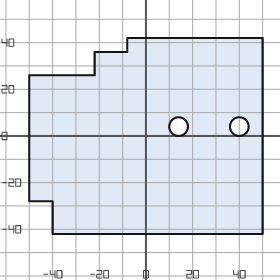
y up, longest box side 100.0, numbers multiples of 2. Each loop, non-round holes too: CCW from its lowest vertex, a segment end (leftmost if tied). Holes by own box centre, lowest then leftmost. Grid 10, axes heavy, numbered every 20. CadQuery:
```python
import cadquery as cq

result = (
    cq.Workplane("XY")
    .moveTo(-40.0, -42.0)
    .lineTo(50.0, -42.0)
    .lineTo(50.0, 42.0)
    .lineTo(-8.0, 42.0)
    .lineTo(-8.0, 36.0)
    .lineTo(-22.0, 36.0)
    .lineTo(-22.0, 26.0)
    .lineTo(-50.0, 26.0)
    .lineTo(-50.0, -28.0)
    .lineTo(-40.0, -28.0)
    .close()
    .moveTo(14.0, 4.0)
    .circle(4.0)
    .moveTo(40.0, 4.0)
    .circle(4.0)
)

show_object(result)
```